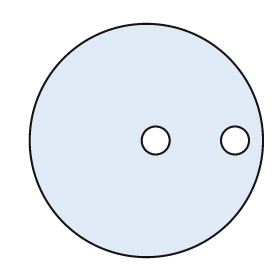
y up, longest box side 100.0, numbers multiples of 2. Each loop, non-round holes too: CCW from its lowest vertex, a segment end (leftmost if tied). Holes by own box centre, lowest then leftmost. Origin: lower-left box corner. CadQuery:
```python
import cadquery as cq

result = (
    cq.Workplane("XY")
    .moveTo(50.0, 50.0)
    .circle(50.0)
    .moveTo(54.0, 50.0)
    .circle(6.0)
    .moveTo(88.0, 50.0)
    .circle(6.0)
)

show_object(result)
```